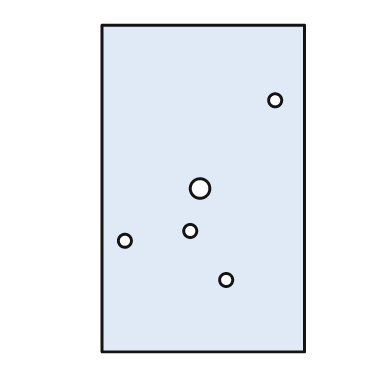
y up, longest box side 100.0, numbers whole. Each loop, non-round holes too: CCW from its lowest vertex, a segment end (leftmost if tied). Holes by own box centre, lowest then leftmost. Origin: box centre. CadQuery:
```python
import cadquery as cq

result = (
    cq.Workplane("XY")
    .moveTo(-31.0, -50.0)
    .lineTo(31.0, -50.0)
    .lineTo(31.0, 50.0)
    .lineTo(-31.0, 50.0)
    .close()
    .moveTo(7.0, -28.0)
    .circle(2.0)
    .moveTo(-24.0, -16.0)
    .circle(2.0)
    .moveTo(-4.0, -13.0)
    .circle(2.0)
    .moveTo(-1.0, 0.0)
    .circle(3.0)
    .moveTo(22.0, 27.0)
    .circle(2.0)
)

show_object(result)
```